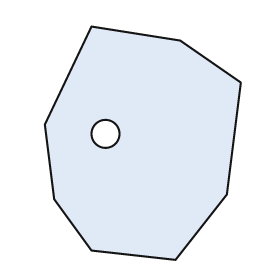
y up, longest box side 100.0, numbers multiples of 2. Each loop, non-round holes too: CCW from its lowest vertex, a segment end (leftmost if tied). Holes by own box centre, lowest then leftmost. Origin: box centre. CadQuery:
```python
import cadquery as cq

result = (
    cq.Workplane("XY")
    .moveTo(14.0, -50.0)
    .lineTo(36.0, -22.0)
    .lineTo(42.0, 26.0)
    .lineTo(16.0, 44.0)
    .lineTo(-22.0, 50.0)
    .lineTo(-42.0, 8.0)
    .lineTo(-38.0, -24.0)
    .lineTo(-22.0, -46.0)
    .close()
    .moveTo(-16.0, 4.0)
    .circle(6.0)
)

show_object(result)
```